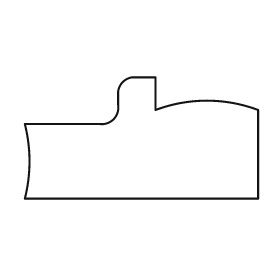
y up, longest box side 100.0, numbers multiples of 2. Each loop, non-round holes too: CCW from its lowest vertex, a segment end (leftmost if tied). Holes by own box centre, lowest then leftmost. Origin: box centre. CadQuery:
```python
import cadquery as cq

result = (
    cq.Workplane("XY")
    .moveTo(-50.0, -26.0)
    .lineTo(50.0, -26.0)
    .lineTo(50.0, 12.0)
    .threePointArc((28.0, 16.0), (6.0, 12.0))
    .lineTo(6.0, 26.0)
    .lineTo(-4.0, 26.0)
    .threePointArc((-8.0, 24.0), (-10.0, 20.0))
    .lineTo(-10.0, 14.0)
    .threePointArc((-12.0, 8.0), (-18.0, 6.0))
    .lineTo(-50.0, 6.0)
    .threePointArc((-48.0, -10.0), (-50.0, -26.0))
    .close()
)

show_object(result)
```